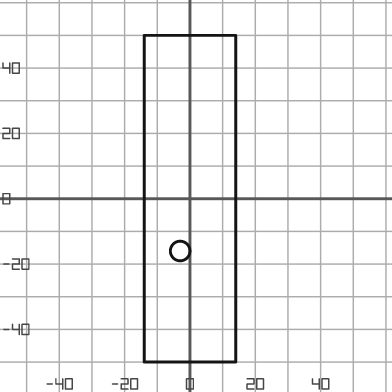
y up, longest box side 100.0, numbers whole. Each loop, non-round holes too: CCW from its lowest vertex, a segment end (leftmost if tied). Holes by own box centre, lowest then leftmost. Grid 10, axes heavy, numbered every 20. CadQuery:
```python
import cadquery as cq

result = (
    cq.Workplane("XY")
    .moveTo(-14.0, -50.0)
    .lineTo(14.0, -50.0)
    .lineTo(14.0, 50.0)
    .lineTo(-14.0, 50.0)
    .close()
    .moveTo(-3.0, -16.0)
    .circle(3.0)
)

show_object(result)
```